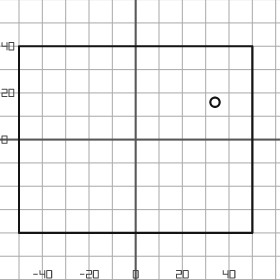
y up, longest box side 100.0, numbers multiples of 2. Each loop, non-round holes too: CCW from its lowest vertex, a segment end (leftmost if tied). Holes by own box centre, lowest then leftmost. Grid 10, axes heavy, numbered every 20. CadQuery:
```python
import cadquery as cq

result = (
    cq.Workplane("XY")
    .moveTo(-50.0, -40.0)
    .lineTo(50.0, -40.0)
    .lineTo(50.0, 40.0)
    .lineTo(-50.0, 40.0)
    .close()
    .moveTo(34.0, 16.0)
    .circle(2.0)
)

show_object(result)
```